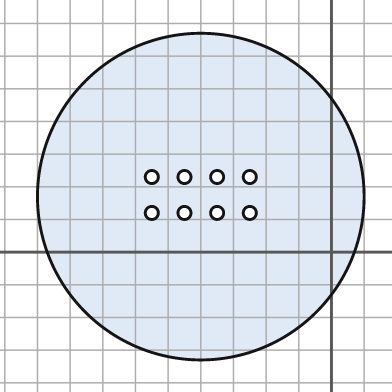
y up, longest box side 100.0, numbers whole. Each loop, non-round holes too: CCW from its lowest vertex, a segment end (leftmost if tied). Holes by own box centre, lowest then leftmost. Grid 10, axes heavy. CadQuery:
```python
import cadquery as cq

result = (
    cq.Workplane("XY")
    .moveTo(-40.0, 17.0)
    .circle(50.0)
    .moveTo(-55.0, 12.0)
    .circle(2.0)
    .moveTo(-45.0, 12.0)
    .circle(2.0)
    .moveTo(-35.0, 12.0)
    .circle(2.0)
    .moveTo(-25.0, 12.0)
    .circle(2.0)
    .moveTo(-55.0, 23.0)
    .circle(2.0)
    .moveTo(-45.0, 23.0)
    .circle(2.0)
    .moveTo(-35.0, 23.0)
    .circle(2.0)
    .moveTo(-25.0, 23.0)
    .circle(2.0)
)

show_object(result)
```